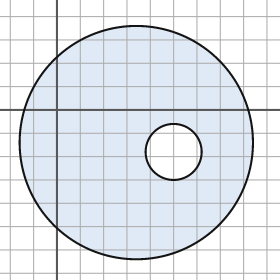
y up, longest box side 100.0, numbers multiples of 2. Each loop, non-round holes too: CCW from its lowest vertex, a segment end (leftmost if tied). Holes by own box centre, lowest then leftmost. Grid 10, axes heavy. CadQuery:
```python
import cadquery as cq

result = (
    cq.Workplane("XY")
    .moveTo(34.0, -14.0)
    .circle(50.0)
    .moveTo(50.0, -18.0)
    .circle(12.0)
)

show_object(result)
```